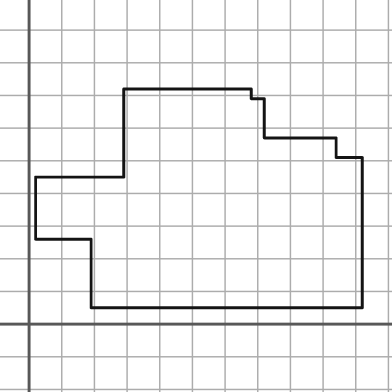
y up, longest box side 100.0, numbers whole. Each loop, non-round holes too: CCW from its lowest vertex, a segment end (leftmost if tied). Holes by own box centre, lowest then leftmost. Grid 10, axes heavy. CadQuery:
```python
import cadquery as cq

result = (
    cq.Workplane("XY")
    .moveTo(19.0, 5.0)
    .lineTo(102.0, 5.0)
    .lineTo(102.0, 51.0)
    .lineTo(94.0, 51.0)
    .lineTo(94.0, 57.0)
    .lineTo(72.0, 57.0)
    .lineTo(72.0, 69.0)
    .lineTo(68.0, 69.0)
    .lineTo(68.0, 72.0)
    .lineTo(29.0, 72.0)
    .lineTo(29.0, 45.0)
    .lineTo(2.0, 45.0)
    .lineTo(2.0, 26.0)
    .lineTo(19.0, 26.0)
    .close()
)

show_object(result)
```